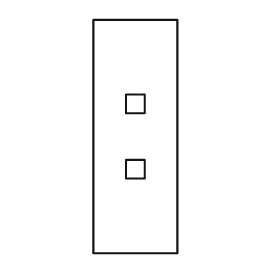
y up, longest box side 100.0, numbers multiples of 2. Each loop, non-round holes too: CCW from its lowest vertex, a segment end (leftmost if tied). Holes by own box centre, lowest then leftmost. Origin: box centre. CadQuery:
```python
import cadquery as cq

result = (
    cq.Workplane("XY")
    .moveTo(-18.0, -50.0)
    .lineTo(18.0, -50.0)
    .lineTo(18.0, 50.0)
    .lineTo(-18.0, 50.0)
    .close()
    .moveTo(-4.0, -18.0)
    .lineTo(4.0, -18.0)
    .lineTo(4.0, -10.0)
    .lineTo(-4.0, -10.0)
    .close()
    .moveTo(-4.0, 10.0)
    .lineTo(4.0, 10.0)
    .lineTo(4.0, 18.0)
    .lineTo(-4.0, 18.0)
    .close()
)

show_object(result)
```